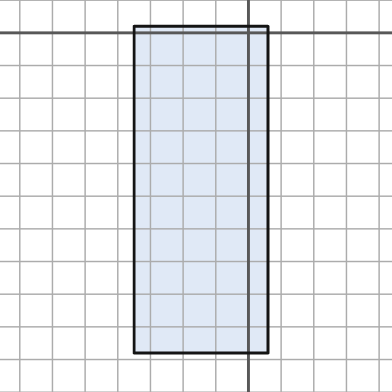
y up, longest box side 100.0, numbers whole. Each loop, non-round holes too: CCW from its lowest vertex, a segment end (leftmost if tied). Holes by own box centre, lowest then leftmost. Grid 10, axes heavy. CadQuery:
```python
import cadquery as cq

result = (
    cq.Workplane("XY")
    .moveTo(-35.0, -98.0)
    .lineTo(6.0, -98.0)
    .lineTo(6.0, 2.0)
    .lineTo(-35.0, 2.0)
    .close()
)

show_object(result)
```